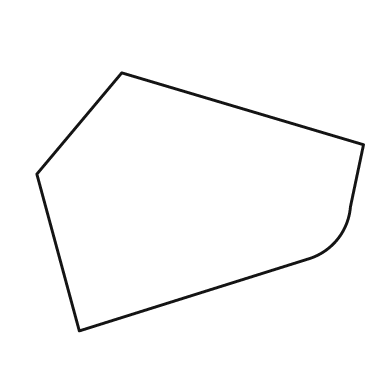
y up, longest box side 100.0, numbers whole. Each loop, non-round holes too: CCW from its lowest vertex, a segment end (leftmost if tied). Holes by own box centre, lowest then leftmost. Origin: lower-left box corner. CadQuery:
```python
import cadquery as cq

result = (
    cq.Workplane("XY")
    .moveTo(13.0, 0.0)
    .lineTo(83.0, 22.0)
    .threePointArc((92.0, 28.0), (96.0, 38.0))
    .lineTo(100.0, 57.0)
    .lineTo(26.0, 79.0)
    .lineTo(0.0, 48.0)
    .close()
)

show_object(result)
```